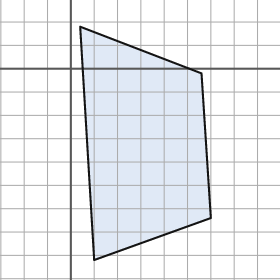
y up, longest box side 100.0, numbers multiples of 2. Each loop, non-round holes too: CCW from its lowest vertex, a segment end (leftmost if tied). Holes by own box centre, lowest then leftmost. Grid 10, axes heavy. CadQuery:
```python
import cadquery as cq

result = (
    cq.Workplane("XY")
    .moveTo(10.0, -82.0)
    .lineTo(60.0, -64.0)
    .lineTo(56.0, -2.0)
    .lineTo(4.0, 18.0)
    .close()
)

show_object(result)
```